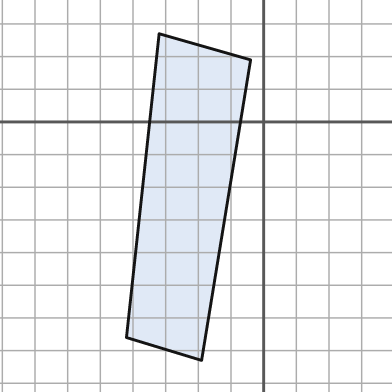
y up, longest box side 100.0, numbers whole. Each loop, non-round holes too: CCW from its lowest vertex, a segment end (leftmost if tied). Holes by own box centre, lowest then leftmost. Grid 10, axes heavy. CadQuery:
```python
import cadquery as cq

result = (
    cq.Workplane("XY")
    .moveTo(-19.0, -73.0)
    .lineTo(-4.0, 19.0)
    .lineTo(-32.0, 27.0)
    .lineTo(-42.0, -66.0)
    .close()
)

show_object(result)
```